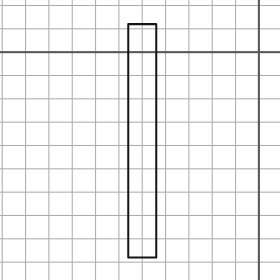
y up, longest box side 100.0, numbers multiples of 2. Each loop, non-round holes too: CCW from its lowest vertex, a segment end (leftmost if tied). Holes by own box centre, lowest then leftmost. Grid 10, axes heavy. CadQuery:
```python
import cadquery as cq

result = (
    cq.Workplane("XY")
    .moveTo(-56.0, -88.0)
    .lineTo(-44.0, -88.0)
    .lineTo(-44.0, 12.0)
    .lineTo(-56.0, 12.0)
    .close()
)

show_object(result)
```